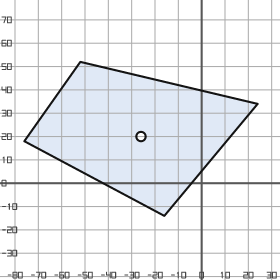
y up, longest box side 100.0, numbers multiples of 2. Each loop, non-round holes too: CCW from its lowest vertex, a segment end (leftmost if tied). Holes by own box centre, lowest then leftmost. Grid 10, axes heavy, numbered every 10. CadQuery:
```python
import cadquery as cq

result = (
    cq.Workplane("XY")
    .moveTo(-16.0, -14.0)
    .lineTo(24.0, 34.0)
    .lineTo(-52.0, 52.0)
    .lineTo(-76.0, 18.0)
    .close()
    .moveTo(-26.0, 20.0)
    .circle(2.0)
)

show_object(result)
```